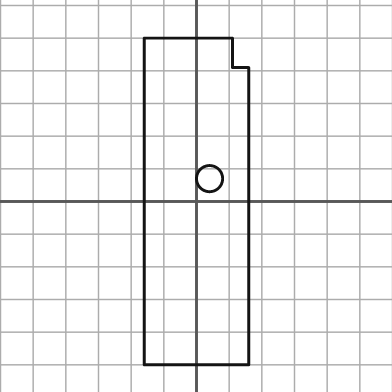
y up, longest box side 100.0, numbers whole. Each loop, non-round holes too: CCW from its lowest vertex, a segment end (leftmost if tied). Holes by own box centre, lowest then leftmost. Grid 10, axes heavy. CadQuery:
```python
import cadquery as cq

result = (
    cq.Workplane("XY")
    .moveTo(-16.0, -50.0)
    .lineTo(16.0, -50.0)
    .lineTo(16.0, 41.0)
    .lineTo(11.0, 41.0)
    .lineTo(11.0, 50.0)
    .lineTo(-16.0, 50.0)
    .close()
    .moveTo(4.0, 7.0)
    .circle(4.0)
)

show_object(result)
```